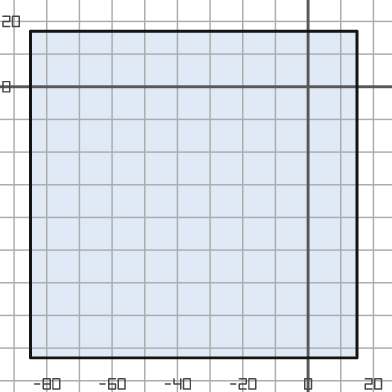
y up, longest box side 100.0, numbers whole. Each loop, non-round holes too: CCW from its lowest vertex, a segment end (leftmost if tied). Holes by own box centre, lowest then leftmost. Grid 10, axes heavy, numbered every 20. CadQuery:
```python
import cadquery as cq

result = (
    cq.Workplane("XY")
    .moveTo(-85.0, -83.0)
    .lineTo(15.0, -83.0)
    .lineTo(15.0, 17.0)
    .lineTo(-85.0, 17.0)
    .close()
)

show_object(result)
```